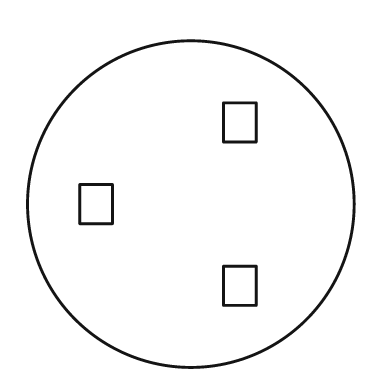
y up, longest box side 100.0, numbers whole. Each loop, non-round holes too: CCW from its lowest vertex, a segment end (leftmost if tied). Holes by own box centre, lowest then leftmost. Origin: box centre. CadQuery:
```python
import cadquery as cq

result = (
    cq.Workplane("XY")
    .moveTo(0.0, 0.0)
    .circle(50.0)
    .moveTo(10.0, -31.0)
    .lineTo(20.0, -31.0)
    .lineTo(20.0, -19.0)
    .lineTo(10.0, -19.0)
    .close()
    .moveTo(-34.0, -6.0)
    .lineTo(-24.0, -6.0)
    .lineTo(-24.0, 6.0)
    .lineTo(-34.0, 6.0)
    .close()
    .moveTo(10.0, 19.0)
    .lineTo(20.0, 19.0)
    .lineTo(20.0, 31.0)
    .lineTo(10.0, 31.0)
    .close()
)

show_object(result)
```